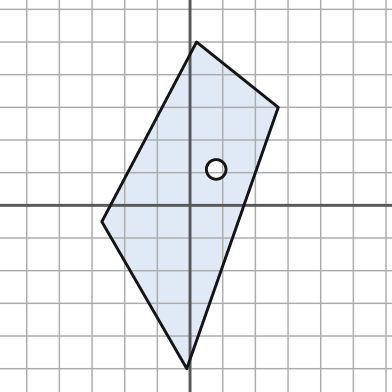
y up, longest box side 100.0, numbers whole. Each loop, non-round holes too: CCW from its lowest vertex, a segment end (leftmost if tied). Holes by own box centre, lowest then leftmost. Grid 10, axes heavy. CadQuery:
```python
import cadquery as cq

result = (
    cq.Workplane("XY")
    .moveTo(-1.0, -50.0)
    .lineTo(27.0, 30.0)
    .lineTo(2.0, 50.0)
    .lineTo(-27.0, -5.0)
    .close()
    .moveTo(8.0, 11.0)
    .circle(3.0)
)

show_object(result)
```